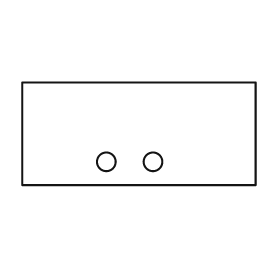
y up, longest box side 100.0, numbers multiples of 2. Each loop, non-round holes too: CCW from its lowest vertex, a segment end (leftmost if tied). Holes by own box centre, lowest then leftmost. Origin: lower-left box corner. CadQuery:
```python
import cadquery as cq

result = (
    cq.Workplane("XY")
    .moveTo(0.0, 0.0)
    .lineTo(100.0, 0.0)
    .lineTo(100.0, 44.0)
    .lineTo(0.0, 44.0)
    .close()
    .moveTo(36.0, 10.0)
    .circle(4.0)
    .moveTo(56.0, 10.0)
    .circle(4.0)
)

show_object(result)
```